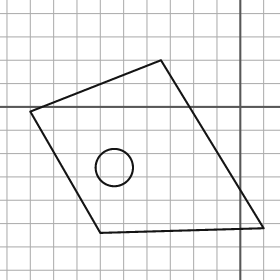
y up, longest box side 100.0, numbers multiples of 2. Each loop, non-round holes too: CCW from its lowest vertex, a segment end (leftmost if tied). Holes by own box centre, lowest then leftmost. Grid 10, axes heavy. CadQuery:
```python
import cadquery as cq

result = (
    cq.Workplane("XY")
    .moveTo(-60.0, -54.0)
    .lineTo(10.0, -52.0)
    .lineTo(-34.0, 20.0)
    .lineTo(-90.0, -2.0)
    .close()
    .moveTo(-54.0, -26.0)
    .circle(8.0)
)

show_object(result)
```